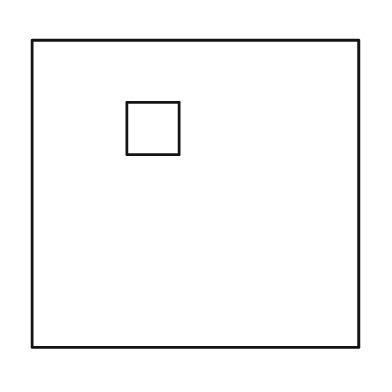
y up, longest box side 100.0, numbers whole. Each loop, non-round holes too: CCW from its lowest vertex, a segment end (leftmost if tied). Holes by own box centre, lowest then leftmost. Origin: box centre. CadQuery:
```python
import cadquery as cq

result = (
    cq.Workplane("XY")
    .moveTo(-50.0, -47.0)
    .lineTo(50.0, -47.0)
    .lineTo(50.0, 47.0)
    .lineTo(-50.0, 47.0)
    .close()
    .moveTo(-21.0, 12.0)
    .lineTo(-5.0, 12.0)
    .lineTo(-5.0, 28.0)
    .lineTo(-21.0, 28.0)
    .close()
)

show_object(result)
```